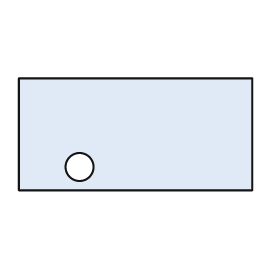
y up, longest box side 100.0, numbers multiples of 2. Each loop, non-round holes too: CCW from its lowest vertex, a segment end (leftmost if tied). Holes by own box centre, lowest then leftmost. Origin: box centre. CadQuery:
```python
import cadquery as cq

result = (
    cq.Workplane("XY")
    .moveTo(-50.0, -24.0)
    .lineTo(50.0, -24.0)
    .lineTo(50.0, 24.0)
    .lineTo(-50.0, 24.0)
    .close()
    .moveTo(-24.0, -14.0)
    .circle(6.0)
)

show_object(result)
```